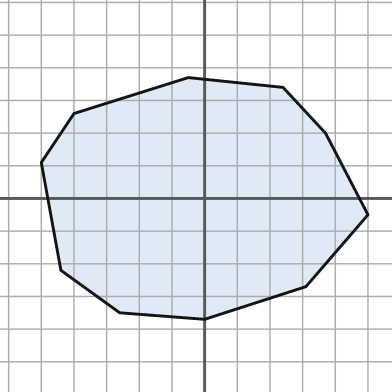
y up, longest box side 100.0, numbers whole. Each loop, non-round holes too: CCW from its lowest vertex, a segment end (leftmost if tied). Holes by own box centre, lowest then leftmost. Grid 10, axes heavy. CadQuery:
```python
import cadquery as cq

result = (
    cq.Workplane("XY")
    .moveTo(0.0, -37.0)
    .lineTo(31.0, -27.0)
    .lineTo(50.0, -5.0)
    .lineTo(37.0, 20.0)
    .lineTo(24.0, 34.0)
    .lineTo(-5.0, 37.0)
    .lineTo(-40.0, 26.0)
    .lineTo(-50.0, 11.0)
    .lineTo(-44.0, -22.0)
    .lineTo(-26.0, -35.0)
    .close()
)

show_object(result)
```